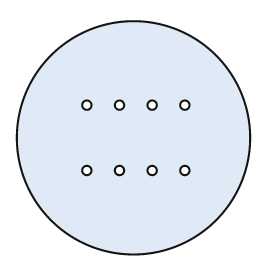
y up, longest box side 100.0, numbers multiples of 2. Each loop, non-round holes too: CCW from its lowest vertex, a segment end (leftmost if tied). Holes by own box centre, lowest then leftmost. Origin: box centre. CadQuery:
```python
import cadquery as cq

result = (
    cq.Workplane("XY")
    .moveTo(0.0, 0.0)
    .circle(50.0)
    .moveTo(-20.0, -14.0)
    .circle(2.0)
    .moveTo(-6.0, -14.0)
    .circle(2.0)
    .moveTo(8.0, -14.0)
    .circle(2.0)
    .moveTo(22.0, -14.0)
    .circle(2.0)
    .moveTo(-20.0, 14.0)
    .circle(2.0)
    .moveTo(-6.0, 14.0)
    .circle(2.0)
    .moveTo(8.0, 14.0)
    .circle(2.0)
    .moveTo(22.0, 14.0)
    .circle(2.0)
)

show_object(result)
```